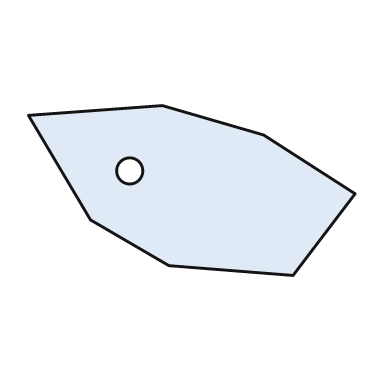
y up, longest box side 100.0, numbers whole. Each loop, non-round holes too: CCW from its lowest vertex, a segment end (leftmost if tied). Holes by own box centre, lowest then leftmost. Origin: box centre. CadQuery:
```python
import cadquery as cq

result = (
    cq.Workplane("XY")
    .moveTo(31.0, -26.0)
    .lineTo(50.0, -1.0)
    .lineTo(22.0, 17.0)
    .lineTo(-9.0, 26.0)
    .lineTo(-50.0, 23.0)
    .lineTo(-31.0, -9.0)
    .lineTo(-7.0, -23.0)
    .close()
    .moveTo(-19.0, 6.0)
    .circle(4.0)
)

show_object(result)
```